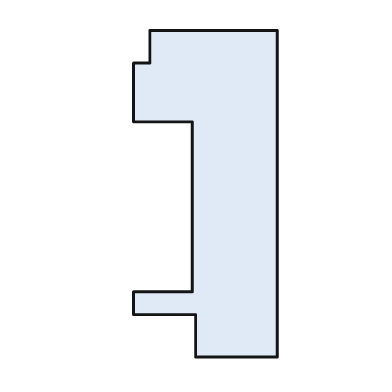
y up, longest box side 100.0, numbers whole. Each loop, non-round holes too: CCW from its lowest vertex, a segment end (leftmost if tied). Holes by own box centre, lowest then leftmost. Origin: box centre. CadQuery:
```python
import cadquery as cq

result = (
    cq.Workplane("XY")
    .moveTo(-3.0, -50.0)
    .lineTo(22.0, -50.0)
    .lineTo(22.0, 50.0)
    .lineTo(-17.0, 50.0)
    .lineTo(-17.0, 40.0)
    .lineTo(-22.0, 40.0)
    .lineTo(-22.0, 22.0)
    .lineTo(-4.0, 22.0)
    .lineTo(-4.0, -30.0)
    .lineTo(-22.0, -30.0)
    .lineTo(-22.0, -37.0)
    .lineTo(-3.0, -37.0)
    .close()
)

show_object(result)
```